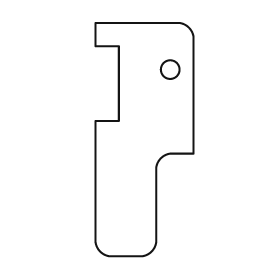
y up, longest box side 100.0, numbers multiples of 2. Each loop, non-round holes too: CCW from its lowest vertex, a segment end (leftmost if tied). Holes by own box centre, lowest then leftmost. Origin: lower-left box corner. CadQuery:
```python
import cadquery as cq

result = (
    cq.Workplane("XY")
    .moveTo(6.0, 0.0)
    .lineTo(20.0, 0.0)
    .threePointArc((24.0, 2.0), (26.0, 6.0))
    .lineTo(26.0, 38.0)
    .threePointArc((28.0, 42.0), (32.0, 44.0))
    .lineTo(42.0, 44.0)
    .lineTo(42.0, 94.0)
    .threePointArc((40.0, 98.0), (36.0, 100.0))
    .lineTo(0.0, 100.0)
    .lineTo(0.0, 90.0)
    .lineTo(10.0, 90.0)
    .lineTo(10.0, 58.0)
    .lineTo(0.0, 58.0)
    .lineTo(0.0, 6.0)
    .threePointArc((2.0, 2.0), (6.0, 0.0))
    .close()
    .moveTo(32.0, 80.0)
    .circle(4.0)
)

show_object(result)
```